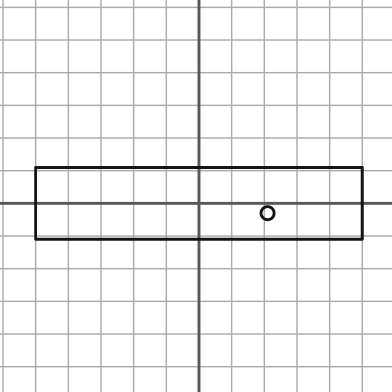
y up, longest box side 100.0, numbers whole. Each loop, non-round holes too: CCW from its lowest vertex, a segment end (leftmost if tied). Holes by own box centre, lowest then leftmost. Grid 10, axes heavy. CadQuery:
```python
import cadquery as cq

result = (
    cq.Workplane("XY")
    .moveTo(-50.0, -11.0)
    .lineTo(50.0, -11.0)
    .lineTo(50.0, 11.0)
    .lineTo(-50.0, 11.0)
    .close()
    .moveTo(21.0, -3.0)
    .circle(2.0)
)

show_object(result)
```